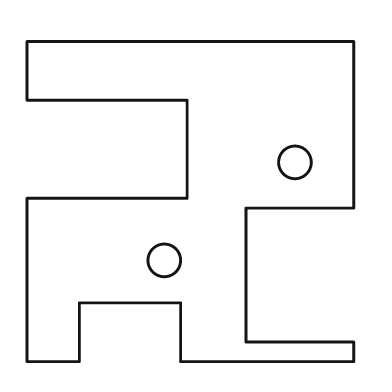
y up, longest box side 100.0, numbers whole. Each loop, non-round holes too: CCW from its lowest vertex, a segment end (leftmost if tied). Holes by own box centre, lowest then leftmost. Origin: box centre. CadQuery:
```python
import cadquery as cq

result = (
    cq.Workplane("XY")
    .moveTo(-50.0, -49.0)
    .lineTo(-34.0, -49.0)
    .lineTo(-34.0, -31.0)
    .lineTo(-3.0, -31.0)
    .lineTo(-3.0, -49.0)
    .lineTo(50.0, -49.0)
    .lineTo(50.0, -43.0)
    .lineTo(17.0, -43.0)
    .lineTo(17.0, -2.0)
    .lineTo(50.0, -2.0)
    .lineTo(50.0, 49.0)
    .lineTo(-50.0, 49.0)
    .lineTo(-50.0, 31.0)
    .lineTo(-1.0, 31.0)
    .lineTo(-1.0, 1.0)
    .lineTo(-50.0, 1.0)
    .close()
    .moveTo(-8.0, -18.0)
    .circle(5.0)
    .moveTo(32.0, 12.0)
    .circle(5.0)
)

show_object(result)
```